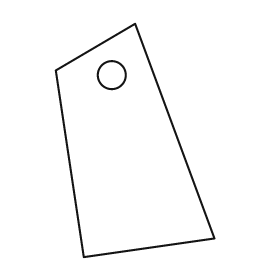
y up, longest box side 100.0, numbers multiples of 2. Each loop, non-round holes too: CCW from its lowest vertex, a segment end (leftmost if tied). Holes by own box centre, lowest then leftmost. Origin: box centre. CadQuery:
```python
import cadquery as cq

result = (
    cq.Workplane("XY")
    .moveTo(-22.0, -50.0)
    .lineTo(34.0, -42.0)
    .lineTo(0.0, 50.0)
    .lineTo(-34.0, 30.0)
    .close()
    .moveTo(-10.0, 28.0)
    .circle(6.0)
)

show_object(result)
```